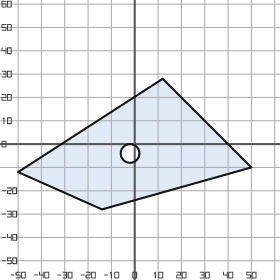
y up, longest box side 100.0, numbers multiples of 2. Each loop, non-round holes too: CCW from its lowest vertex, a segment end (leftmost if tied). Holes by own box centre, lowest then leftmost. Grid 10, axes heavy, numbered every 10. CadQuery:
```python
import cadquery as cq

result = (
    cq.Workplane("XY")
    .moveTo(-14.0, -28.0)
    .lineTo(50.0, -10.0)
    .lineTo(12.0, 28.0)
    .lineTo(-50.0, -12.0)
    .close()
    .moveTo(-2.0, -4.0)
    .circle(4.0)
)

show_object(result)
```